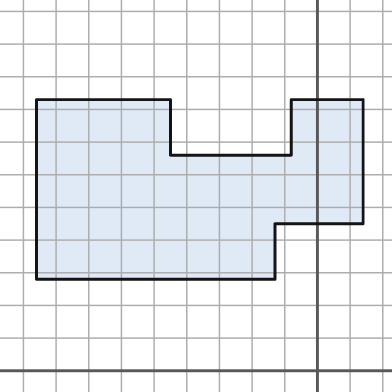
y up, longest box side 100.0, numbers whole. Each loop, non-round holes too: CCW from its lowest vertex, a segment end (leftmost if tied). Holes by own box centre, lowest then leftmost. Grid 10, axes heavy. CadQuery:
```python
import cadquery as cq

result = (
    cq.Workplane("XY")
    .moveTo(-86.0, 28.0)
    .lineTo(-13.0, 28.0)
    .lineTo(-13.0, 45.0)
    .lineTo(14.0, 45.0)
    .lineTo(14.0, 83.0)
    .lineTo(-8.0, 83.0)
    .lineTo(-8.0, 66.0)
    .lineTo(-45.0, 66.0)
    .lineTo(-45.0, 83.0)
    .lineTo(-86.0, 83.0)
    .close()
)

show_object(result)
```